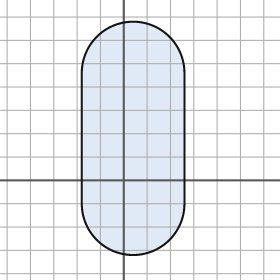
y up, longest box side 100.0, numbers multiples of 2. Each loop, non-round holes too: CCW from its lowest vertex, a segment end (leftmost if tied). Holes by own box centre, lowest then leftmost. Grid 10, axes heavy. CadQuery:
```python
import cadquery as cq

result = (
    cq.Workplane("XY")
    .moveTo(-18.0, -10.0)
    .threePointArc((4.0, -32.0), (26.0, -10.0))
    .lineTo(26.0, 46.0)
    .threePointArc((4.0, 68.0), (-18.0, 46.0))
    .close()
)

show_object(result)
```